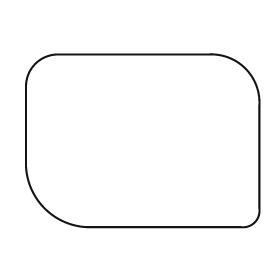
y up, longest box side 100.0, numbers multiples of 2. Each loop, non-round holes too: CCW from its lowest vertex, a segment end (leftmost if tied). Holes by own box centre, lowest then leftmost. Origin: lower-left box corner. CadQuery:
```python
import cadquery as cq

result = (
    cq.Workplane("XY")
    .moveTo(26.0, 0.0)
    .lineTo(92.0, 0.0)
    .threePointArc((98.0, 2.0), (100.0, 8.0))
    .lineTo(100.0, 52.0)
    .threePointArc((94.0, 68.0), (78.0, 74.0))
    .lineTo(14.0, 74.0)
    .threePointArc((4.0, 70.0), (0.0, 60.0))
    .lineTo(0.0, 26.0)
    .threePointArc((8.0, 8.0), (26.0, 0.0))
    .close()
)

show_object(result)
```